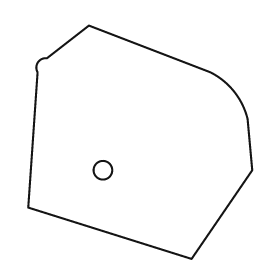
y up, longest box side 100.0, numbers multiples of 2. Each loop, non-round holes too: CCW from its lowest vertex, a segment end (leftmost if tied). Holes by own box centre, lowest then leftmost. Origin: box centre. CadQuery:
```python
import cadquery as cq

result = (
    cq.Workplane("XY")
    .moveTo(22.0, -50.0)
    .lineTo(48.0, -12.0)
    .lineTo(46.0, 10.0)
    .threePointArc((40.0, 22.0), (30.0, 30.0))
    .lineTo(-22.0, 50.0)
    .lineTo(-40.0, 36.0)
    .threePointArc((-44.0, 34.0), (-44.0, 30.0))
    .lineTo(-48.0, -28.0)
    .close()
    .moveTo(-16.0, -12.0)
    .circle(4.0)
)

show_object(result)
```